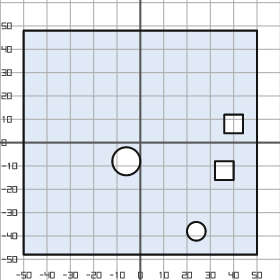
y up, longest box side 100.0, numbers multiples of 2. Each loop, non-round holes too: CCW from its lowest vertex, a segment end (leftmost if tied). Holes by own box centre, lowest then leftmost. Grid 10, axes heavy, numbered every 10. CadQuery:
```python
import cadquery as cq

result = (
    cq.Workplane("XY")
    .moveTo(-50.0, -48.0)
    .lineTo(50.0, -48.0)
    .lineTo(50.0, 48.0)
    .lineTo(-50.0, 48.0)
    .close()
    .moveTo(24.0, -38.0)
    .circle(4.0)
    .moveTo(32.0, -16.0)
    .lineTo(40.0, -16.0)
    .lineTo(40.0, -8.0)
    .lineTo(32.0, -8.0)
    .close()
    .moveTo(-6.0, -8.0)
    .circle(6.0)
    .moveTo(36.0, 4.0)
    .lineTo(44.0, 4.0)
    .lineTo(44.0, 12.0)
    .lineTo(36.0, 12.0)
    .close()
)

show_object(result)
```